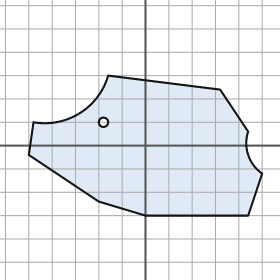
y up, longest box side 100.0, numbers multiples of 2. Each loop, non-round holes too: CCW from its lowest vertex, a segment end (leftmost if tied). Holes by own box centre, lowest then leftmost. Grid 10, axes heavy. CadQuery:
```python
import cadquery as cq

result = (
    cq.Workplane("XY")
    .moveTo(0.0, -30.0)
    .lineTo(44.0, -30.0)
    .lineTo(50.0, -12.0)
    .threePointArc((44.0, -4.0), (44.0, 6.0))
    .lineTo(32.0, 24.0)
    .lineTo(-16.0, 30.0)
    .threePointArc((-28.0, 14.0), (-48.0, 10.0))
    .lineTo(-50.0, -4.0)
    .lineTo(-20.0, -24.0)
    .close()
    .moveTo(-18.0, 10.0)
    .circle(2.0)
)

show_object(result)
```